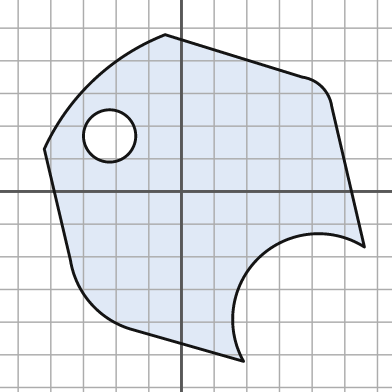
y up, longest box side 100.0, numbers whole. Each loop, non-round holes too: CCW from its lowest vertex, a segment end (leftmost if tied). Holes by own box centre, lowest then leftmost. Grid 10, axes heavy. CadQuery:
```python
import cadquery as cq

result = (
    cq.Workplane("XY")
    .moveTo(19.0, -52.0)
    .threePointArc((24.0, -20.0), (56.0, -17.0))
    .lineTo(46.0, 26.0)
    .threePointArc((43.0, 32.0), (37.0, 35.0))
    .lineTo(-5.0, 48.0)
    .threePointArc((-27.0, 34.0), (-42.0, 13.0))
    .lineTo(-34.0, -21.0)
    .threePointArc((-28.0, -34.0), (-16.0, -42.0))
    .close()
    .moveTo(-22.0, 17.0)
    .circle(8.0)
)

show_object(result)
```